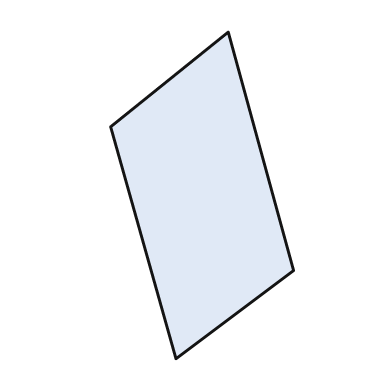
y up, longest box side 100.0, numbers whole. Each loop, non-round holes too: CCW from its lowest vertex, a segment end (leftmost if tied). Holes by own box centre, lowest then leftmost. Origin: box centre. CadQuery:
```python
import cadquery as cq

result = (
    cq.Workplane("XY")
    .moveTo(-8.0, -50.0)
    .lineTo(28.0, -23.0)
    .lineTo(8.0, 50.0)
    .lineTo(-28.0, 21.0)
    .close()
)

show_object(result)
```